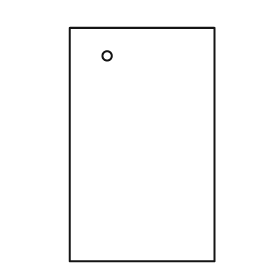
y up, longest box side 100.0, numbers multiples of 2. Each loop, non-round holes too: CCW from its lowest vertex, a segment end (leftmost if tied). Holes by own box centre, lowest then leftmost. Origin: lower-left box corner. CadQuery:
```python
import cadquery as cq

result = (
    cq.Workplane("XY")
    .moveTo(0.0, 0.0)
    .lineTo(62.0, 0.0)
    .lineTo(62.0, 100.0)
    .lineTo(0.0, 100.0)
    .close()
    .moveTo(16.0, 88.0)
    .circle(2.0)
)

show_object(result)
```